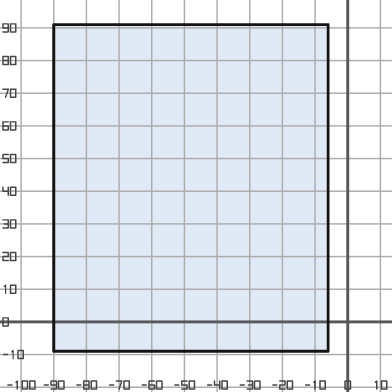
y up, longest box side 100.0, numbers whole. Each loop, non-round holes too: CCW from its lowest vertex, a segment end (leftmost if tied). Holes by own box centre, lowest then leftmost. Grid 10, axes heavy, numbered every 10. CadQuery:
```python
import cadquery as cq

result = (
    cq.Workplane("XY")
    .moveTo(-90.0, -9.0)
    .lineTo(-6.0, -9.0)
    .lineTo(-6.0, 91.0)
    .lineTo(-90.0, 91.0)
    .close()
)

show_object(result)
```